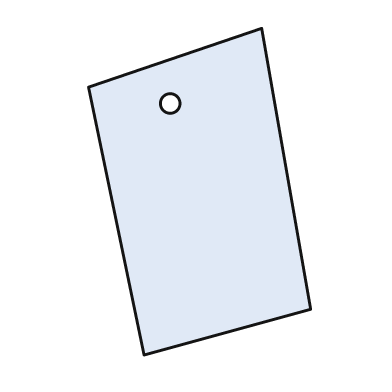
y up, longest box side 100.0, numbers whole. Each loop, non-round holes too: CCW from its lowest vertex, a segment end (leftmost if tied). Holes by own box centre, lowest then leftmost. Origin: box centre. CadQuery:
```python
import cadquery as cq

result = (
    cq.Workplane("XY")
    .moveTo(-17.0, -50.0)
    .lineTo(34.0, -36.0)
    .lineTo(19.0, 50.0)
    .lineTo(-34.0, 32.0)
    .close()
    .moveTo(-9.0, 27.0)
    .circle(3.0)
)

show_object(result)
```